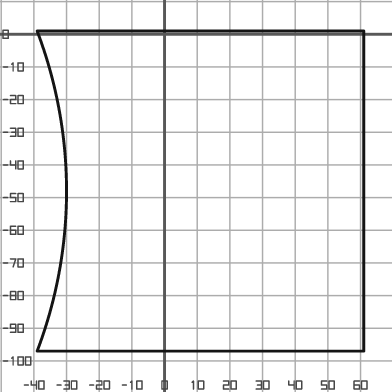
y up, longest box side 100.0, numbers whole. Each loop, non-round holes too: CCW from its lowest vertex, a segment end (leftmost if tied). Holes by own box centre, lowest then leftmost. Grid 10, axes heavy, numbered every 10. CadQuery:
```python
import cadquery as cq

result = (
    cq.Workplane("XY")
    .moveTo(-39.0, -97.0)
    .lineTo(61.0, -97.0)
    .lineTo(61.0, 1.0)
    .lineTo(-39.0, 1.0)
    .threePointArc((-30.0, -48.0), (-39.0, -97.0))
    .close()
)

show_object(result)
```